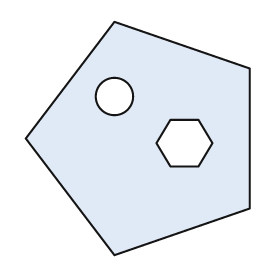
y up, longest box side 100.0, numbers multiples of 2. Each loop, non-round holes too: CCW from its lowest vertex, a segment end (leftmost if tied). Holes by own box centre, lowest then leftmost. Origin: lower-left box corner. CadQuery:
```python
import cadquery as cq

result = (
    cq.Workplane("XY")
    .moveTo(38.0, 0.0)
    .lineTo(96.0, 20.0)
    .lineTo(96.0, 80.0)
    .lineTo(38.0, 100.0)
    .lineTo(0.0, 50.0)
    .close()
    .moveTo(62.0, 38.0)
    .lineTo(74.0, 38.0)
    .lineTo(80.0, 48.0)
    .lineTo(74.0, 58.0)
    .lineTo(62.0, 58.0)
    .lineTo(56.0, 48.0)
    .close()
    .moveTo(38.0, 68.0)
    .circle(8.0)
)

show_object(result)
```